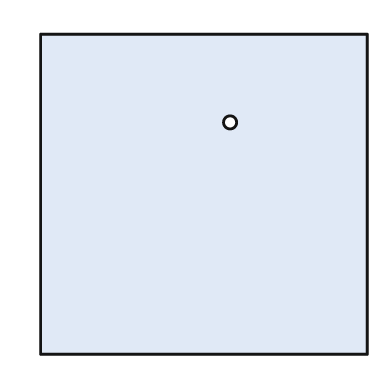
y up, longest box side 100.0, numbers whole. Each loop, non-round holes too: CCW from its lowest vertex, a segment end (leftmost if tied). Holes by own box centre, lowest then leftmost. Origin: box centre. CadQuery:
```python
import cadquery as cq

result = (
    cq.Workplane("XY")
    .moveTo(-50.0, -49.0)
    .lineTo(50.0, -49.0)
    .lineTo(50.0, 49.0)
    .lineTo(-50.0, 49.0)
    .close()
    .moveTo(8.0, 22.0)
    .circle(2.0)
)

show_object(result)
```